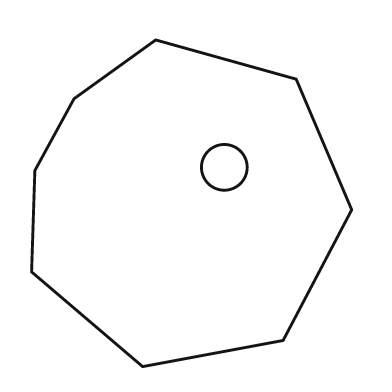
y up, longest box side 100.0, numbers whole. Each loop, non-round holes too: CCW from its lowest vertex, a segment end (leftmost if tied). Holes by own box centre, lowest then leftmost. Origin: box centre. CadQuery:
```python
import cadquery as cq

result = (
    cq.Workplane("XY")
    .moveTo(-15.0, -50.0)
    .lineTo(28.0, -42.0)
    .lineTo(49.0, -2.0)
    .lineTo(32.0, 38.0)
    .lineTo(-11.0, 50.0)
    .lineTo(-36.0, 32.0)
    .lineTo(-48.0, 10.0)
    .lineTo(-49.0, -21.0)
    .close()
    .moveTo(10.0, 11.0)
    .circle(7.0)
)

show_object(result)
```